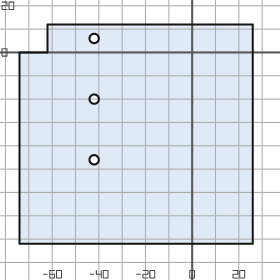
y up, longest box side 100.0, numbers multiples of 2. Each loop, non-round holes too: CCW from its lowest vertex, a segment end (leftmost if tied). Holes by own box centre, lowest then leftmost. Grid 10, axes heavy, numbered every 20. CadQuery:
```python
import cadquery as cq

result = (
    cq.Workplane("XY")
    .moveTo(-74.0, -82.0)
    .lineTo(26.0, -82.0)
    .lineTo(26.0, 12.0)
    .lineTo(-62.0, 12.0)
    .lineTo(-62.0, 0.0)
    .lineTo(-74.0, 0.0)
    .close()
    .moveTo(-42.0, -46.0)
    .circle(2.0)
    .moveTo(-42.0, -20.0)
    .circle(2.0)
    .moveTo(-42.0, 6.0)
    .circle(2.0)
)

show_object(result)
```